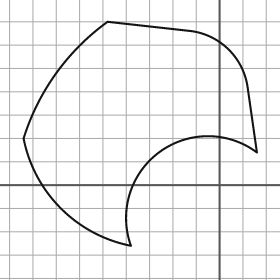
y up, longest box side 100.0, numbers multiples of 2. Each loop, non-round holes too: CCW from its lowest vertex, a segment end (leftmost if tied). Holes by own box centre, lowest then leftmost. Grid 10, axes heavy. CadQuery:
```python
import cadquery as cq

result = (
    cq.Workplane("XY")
    .moveTo(-38.0, -26.0)
    .threePointArc((-26.0, 14.0), (16.0, 14.0))
    .lineTo(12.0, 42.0)
    .threePointArc((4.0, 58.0), (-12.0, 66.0))
    .lineTo(-48.0, 70.0)
    .threePointArc((-70.0, 48.0), (-84.0, 20.0))
    .threePointArc((-68.0, -10.0), (-38.0, -26.0))
    .close()
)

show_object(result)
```